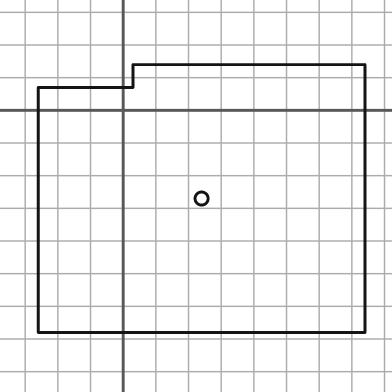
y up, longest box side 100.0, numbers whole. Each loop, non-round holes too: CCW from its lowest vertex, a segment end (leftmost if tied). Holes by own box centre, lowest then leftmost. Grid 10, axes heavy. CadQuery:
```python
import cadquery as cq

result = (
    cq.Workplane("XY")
    .moveTo(-26.0, -68.0)
    .lineTo(74.0, -68.0)
    .lineTo(74.0, 14.0)
    .lineTo(3.0, 14.0)
    .lineTo(3.0, 7.0)
    .lineTo(-26.0, 7.0)
    .close()
    .moveTo(24.0, -27.0)
    .circle(2.0)
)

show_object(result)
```